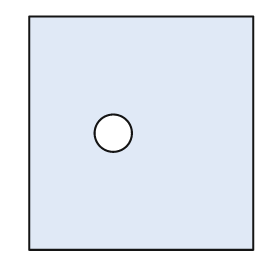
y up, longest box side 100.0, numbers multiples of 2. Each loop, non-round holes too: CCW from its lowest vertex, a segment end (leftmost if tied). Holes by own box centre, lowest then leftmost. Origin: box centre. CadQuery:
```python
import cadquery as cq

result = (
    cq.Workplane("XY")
    .moveTo(-48.0, -50.0)
    .lineTo(48.0, -50.0)
    .lineTo(48.0, 50.0)
    .lineTo(-48.0, 50.0)
    .close()
    .moveTo(-12.0, 0.0)
    .circle(8.0)
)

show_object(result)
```